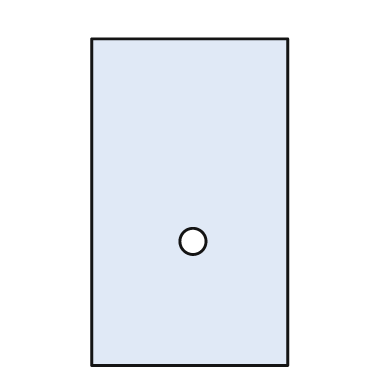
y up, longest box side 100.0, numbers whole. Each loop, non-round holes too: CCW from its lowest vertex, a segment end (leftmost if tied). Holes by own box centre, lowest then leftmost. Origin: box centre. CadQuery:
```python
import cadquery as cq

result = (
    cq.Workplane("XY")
    .moveTo(-30.0, -50.0)
    .lineTo(30.0, -50.0)
    .lineTo(30.0, 50.0)
    .lineTo(-30.0, 50.0)
    .close()
    .moveTo(1.0, -12.0)
    .circle(4.0)
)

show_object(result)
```